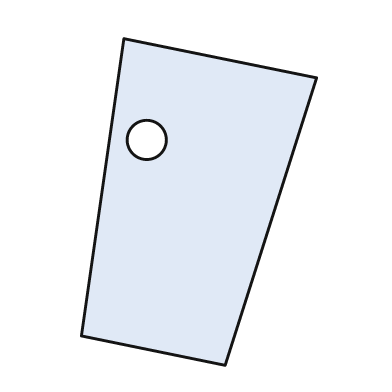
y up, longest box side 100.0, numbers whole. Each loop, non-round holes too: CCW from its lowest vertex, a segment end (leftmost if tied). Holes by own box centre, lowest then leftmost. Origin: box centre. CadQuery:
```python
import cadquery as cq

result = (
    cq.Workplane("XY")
    .moveTo(8.0, -50.0)
    .lineTo(36.0, 38.0)
    .lineTo(-23.0, 50.0)
    .lineTo(-36.0, -41.0)
    .close()
    .moveTo(-16.0, 19.0)
    .circle(6.0)
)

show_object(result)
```